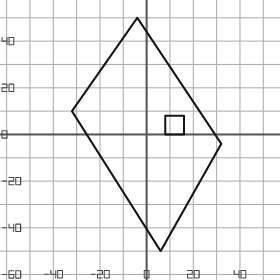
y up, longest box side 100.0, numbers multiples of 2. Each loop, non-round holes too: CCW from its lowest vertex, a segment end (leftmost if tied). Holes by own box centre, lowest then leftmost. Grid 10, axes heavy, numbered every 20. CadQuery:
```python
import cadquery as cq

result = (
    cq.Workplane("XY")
    .moveTo(6.0, -50.0)
    .lineTo(32.0, -4.0)
    .lineTo(-4.0, 50.0)
    .lineTo(-32.0, 10.0)
    .close()
    .moveTo(8.0, 0.0)
    .lineTo(16.0, 0.0)
    .lineTo(16.0, 8.0)
    .lineTo(8.0, 8.0)
    .close()
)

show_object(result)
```